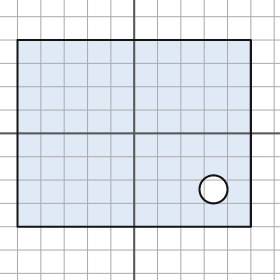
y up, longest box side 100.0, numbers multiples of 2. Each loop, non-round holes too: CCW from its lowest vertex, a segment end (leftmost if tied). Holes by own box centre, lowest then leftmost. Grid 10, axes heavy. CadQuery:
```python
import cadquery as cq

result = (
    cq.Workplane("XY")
    .moveTo(-50.0, -40.0)
    .lineTo(50.0, -40.0)
    .lineTo(50.0, 40.0)
    .lineTo(-50.0, 40.0)
    .close()
    .moveTo(34.0, -24.0)
    .circle(6.0)
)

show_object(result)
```